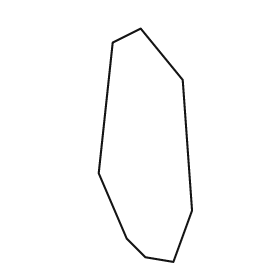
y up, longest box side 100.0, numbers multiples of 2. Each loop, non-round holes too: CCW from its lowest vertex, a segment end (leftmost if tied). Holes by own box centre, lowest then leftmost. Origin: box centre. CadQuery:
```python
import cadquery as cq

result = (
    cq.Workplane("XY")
    .moveTo(12.0, -50.0)
    .lineTo(20.0, -28.0)
    .lineTo(16.0, 28.0)
    .lineTo(-2.0, 50.0)
    .lineTo(-14.0, 44.0)
    .lineTo(-20.0, -12.0)
    .lineTo(-8.0, -40.0)
    .lineTo(0.0, -48.0)
    .close()
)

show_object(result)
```